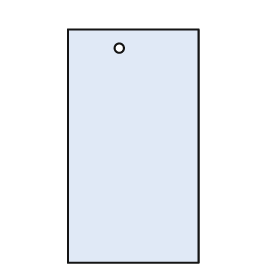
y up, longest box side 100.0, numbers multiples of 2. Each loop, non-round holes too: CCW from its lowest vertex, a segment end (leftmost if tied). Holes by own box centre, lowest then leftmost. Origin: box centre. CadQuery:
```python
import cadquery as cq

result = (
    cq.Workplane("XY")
    .moveTo(-28.0, -50.0)
    .lineTo(28.0, -50.0)
    .lineTo(28.0, 50.0)
    .lineTo(-28.0, 50.0)
    .close()
    .moveTo(-6.0, 42.0)
    .circle(2.0)
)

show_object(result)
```